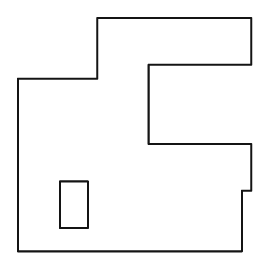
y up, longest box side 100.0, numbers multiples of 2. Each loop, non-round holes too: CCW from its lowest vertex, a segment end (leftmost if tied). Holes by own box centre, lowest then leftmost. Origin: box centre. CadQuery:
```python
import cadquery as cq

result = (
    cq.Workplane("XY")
    .moveTo(-50.0, -50.0)
    .lineTo(46.0, -50.0)
    .lineTo(46.0, -24.0)
    .lineTo(50.0, -24.0)
    .lineTo(50.0, -4.0)
    .lineTo(6.0, -4.0)
    .lineTo(6.0, 30.0)
    .lineTo(50.0, 30.0)
    .lineTo(50.0, 50.0)
    .lineTo(-16.0, 50.0)
    .lineTo(-16.0, 24.0)
    .lineTo(-50.0, 24.0)
    .close()
    .moveTo(-32.0, -40.0)
    .lineTo(-20.0, -40.0)
    .lineTo(-20.0, -20.0)
    .lineTo(-32.0, -20.0)
    .close()
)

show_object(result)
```